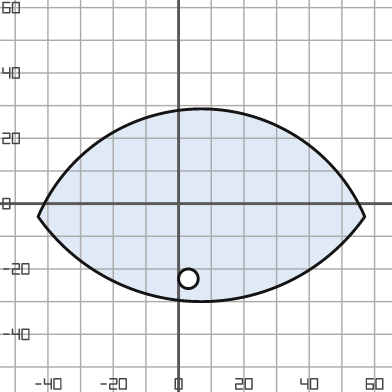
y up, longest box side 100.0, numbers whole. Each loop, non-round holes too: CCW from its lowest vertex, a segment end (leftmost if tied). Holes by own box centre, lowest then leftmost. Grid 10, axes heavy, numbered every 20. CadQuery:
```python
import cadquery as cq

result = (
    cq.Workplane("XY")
    .moveTo(-43.0, -4.0)
    .threePointArc((7.0, -30.0), (57.0, -4.0))
    .threePointArc((7.0, 29.0), (-43.0, -4.0))
    .close()
    .moveTo(3.0, -23.0)
    .circle(3.0)
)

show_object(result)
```